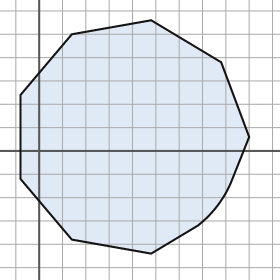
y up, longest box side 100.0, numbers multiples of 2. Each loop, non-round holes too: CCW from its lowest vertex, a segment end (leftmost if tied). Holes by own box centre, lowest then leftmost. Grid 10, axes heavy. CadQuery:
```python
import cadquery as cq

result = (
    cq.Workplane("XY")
    .moveTo(48.0, -44.0)
    .lineTo(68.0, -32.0)
    .threePointArc((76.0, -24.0), (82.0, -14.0))
    .lineTo(90.0, 6.0)
    .lineTo(78.0, 38.0)
    .lineTo(48.0, 56.0)
    .lineTo(14.0, 50.0)
    .lineTo(-8.0, 24.0)
    .lineTo(-8.0, -12.0)
    .lineTo(14.0, -38.0)
    .close()
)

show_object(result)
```